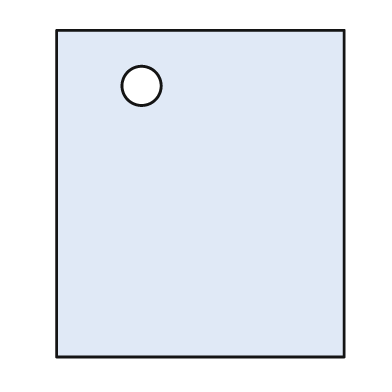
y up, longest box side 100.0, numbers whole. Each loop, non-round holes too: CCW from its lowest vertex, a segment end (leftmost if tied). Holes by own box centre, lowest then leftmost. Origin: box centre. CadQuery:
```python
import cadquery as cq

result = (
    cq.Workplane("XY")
    .moveTo(-44.0, -50.0)
    .lineTo(44.0, -50.0)
    .lineTo(44.0, 50.0)
    .lineTo(-44.0, 50.0)
    .close()
    .moveTo(-18.0, 33.0)
    .circle(6.0)
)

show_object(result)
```